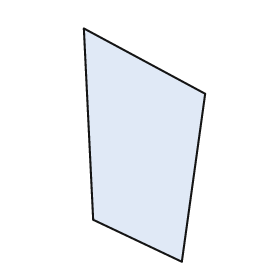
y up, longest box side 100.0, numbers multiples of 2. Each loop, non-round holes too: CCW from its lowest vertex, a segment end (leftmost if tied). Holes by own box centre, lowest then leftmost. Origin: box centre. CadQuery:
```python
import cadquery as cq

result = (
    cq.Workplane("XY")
    .moveTo(16.0, -50.0)
    .lineTo(26.0, 22.0)
    .lineTo(-26.0, 50.0)
    .lineTo(-22.0, -32.0)
    .close()
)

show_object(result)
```